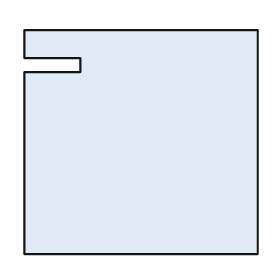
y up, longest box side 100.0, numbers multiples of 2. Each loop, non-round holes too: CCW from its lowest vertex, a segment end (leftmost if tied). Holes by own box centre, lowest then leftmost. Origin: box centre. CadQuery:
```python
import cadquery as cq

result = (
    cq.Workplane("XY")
    .moveTo(-50.0, -48.0)
    .lineTo(50.0, -48.0)
    .lineTo(50.0, 48.0)
    .lineTo(-50.0, 48.0)
    .lineTo(-50.0, 36.0)
    .lineTo(-26.0, 36.0)
    .lineTo(-26.0, 30.0)
    .lineTo(-50.0, 30.0)
    .close()
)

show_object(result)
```